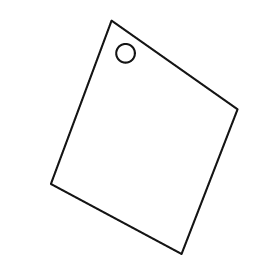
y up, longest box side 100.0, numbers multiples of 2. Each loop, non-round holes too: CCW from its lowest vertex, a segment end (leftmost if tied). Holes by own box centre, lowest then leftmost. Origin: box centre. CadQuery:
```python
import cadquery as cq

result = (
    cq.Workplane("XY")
    .moveTo(16.0, -50.0)
    .lineTo(40.0, 12.0)
    .lineTo(-14.0, 50.0)
    .lineTo(-40.0, -20.0)
    .close()
    .moveTo(-8.0, 36.0)
    .circle(4.0)
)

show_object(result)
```